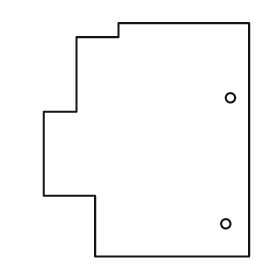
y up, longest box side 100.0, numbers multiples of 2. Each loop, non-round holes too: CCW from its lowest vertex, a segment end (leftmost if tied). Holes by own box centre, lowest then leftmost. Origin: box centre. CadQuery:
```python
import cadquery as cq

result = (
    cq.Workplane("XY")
    .moveTo(-22.0, -50.0)
    .lineTo(44.0, -50.0)
    .lineTo(44.0, 50.0)
    .lineTo(-12.0, 50.0)
    .lineTo(-12.0, 44.0)
    .lineTo(-30.0, 44.0)
    .lineTo(-30.0, 12.0)
    .lineTo(-44.0, 12.0)
    .lineTo(-44.0, -24.0)
    .lineTo(-22.0, -24.0)
    .close()
    .moveTo(34.0, -36.0)
    .circle(2.0)
    .moveTo(36.0, 18.0)
    .circle(2.0)
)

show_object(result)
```